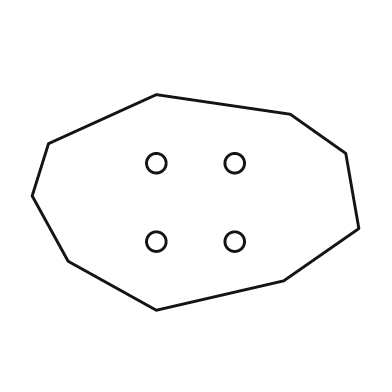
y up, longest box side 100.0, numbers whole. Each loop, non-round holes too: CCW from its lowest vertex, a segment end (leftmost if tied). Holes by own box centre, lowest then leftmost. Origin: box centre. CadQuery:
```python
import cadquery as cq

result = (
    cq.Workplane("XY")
    .moveTo(-12.0, -33.0)
    .lineTo(27.0, -24.0)
    .lineTo(50.0, -8.0)
    .lineTo(46.0, 15.0)
    .lineTo(29.0, 27.0)
    .lineTo(-12.0, 33.0)
    .lineTo(-45.0, 18.0)
    .lineTo(-50.0, 2.0)
    .lineTo(-39.0, -18.0)
    .close()
    .moveTo(-12.0, -12.0)
    .circle(3.0)
    .moveTo(12.0, -12.0)
    .circle(3.0)
    .moveTo(-12.0, 12.0)
    .circle(3.0)
    .moveTo(12.0, 12.0)
    .circle(3.0)
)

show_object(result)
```